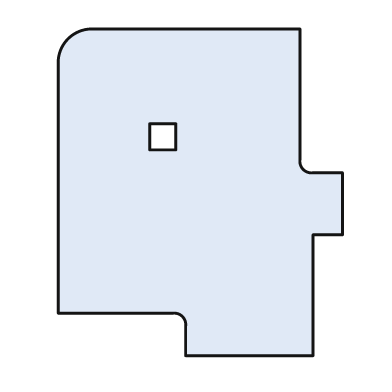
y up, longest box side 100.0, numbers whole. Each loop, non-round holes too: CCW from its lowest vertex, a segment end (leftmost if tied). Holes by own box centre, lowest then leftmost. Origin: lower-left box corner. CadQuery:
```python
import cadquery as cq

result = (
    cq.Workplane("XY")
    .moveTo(39.0, 0.0)
    .lineTo(78.0, 0.0)
    .lineTo(78.0, 37.0)
    .lineTo(87.0, 37.0)
    .lineTo(87.0, 56.0)
    .lineTo(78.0, 56.0)
    .threePointArc((75.0, 57.0), (74.0, 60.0))
    .lineTo(74.0, 100.0)
    .lineTo(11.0, 100.0)
    .threePointArc((3.0, 97.0), (0.0, 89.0))
    .lineTo(0.0, 13.0)
    .lineTo(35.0, 13.0)
    .threePointArc((38.0, 12.0), (39.0, 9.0))
    .close()
    .moveTo(28.0, 63.0)
    .lineTo(36.0, 63.0)
    .lineTo(36.0, 71.0)
    .lineTo(28.0, 71.0)
    .close()
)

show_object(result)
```